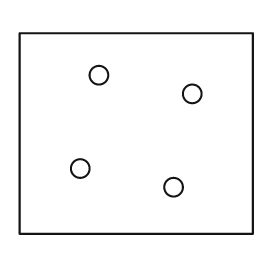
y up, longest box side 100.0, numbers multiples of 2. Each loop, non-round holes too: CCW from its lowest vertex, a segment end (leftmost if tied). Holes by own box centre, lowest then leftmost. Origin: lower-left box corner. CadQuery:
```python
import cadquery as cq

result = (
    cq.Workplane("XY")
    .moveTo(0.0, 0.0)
    .lineTo(100.0, 0.0)
    .lineTo(100.0, 86.0)
    .lineTo(0.0, 86.0)
    .close()
    .moveTo(66.0, 20.0)
    .circle(4.0)
    .moveTo(26.0, 28.0)
    .circle(4.0)
    .moveTo(74.0, 60.0)
    .circle(4.0)
    .moveTo(34.0, 68.0)
    .circle(4.0)
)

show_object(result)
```